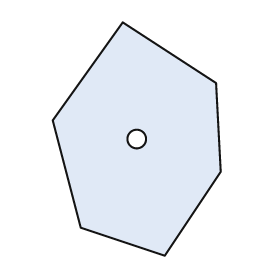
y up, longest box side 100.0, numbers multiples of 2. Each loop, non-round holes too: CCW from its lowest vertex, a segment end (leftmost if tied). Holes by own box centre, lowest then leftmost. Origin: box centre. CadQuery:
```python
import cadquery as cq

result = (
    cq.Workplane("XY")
    .moveTo(12.0, -50.0)
    .lineTo(36.0, -14.0)
    .lineTo(34.0, 24.0)
    .lineTo(-6.0, 50.0)
    .lineTo(-36.0, 8.0)
    .lineTo(-24.0, -38.0)
    .close()
    .moveTo(0.0, 0.0)
    .circle(4.0)
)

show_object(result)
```